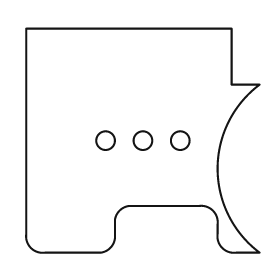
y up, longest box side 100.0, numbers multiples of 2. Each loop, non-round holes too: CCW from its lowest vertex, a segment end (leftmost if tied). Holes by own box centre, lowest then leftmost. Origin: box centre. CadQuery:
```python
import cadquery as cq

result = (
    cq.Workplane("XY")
    .moveTo(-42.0, -48.0)
    .lineTo(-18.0, -48.0)
    .threePointArc((-14.0, -46.0), (-12.0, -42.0))
    .lineTo(-12.0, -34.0)
    .threePointArc((-10.0, -30.0), (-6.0, -28.0))
    .lineTo(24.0, -28.0)
    .threePointArc((30.0, -30.0), (32.0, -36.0))
    .lineTo(32.0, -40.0)
    .threePointArc((34.0, -46.0), (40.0, -48.0))
    .lineTo(50.0, -48.0)
    .threePointArc((32.0, -12.0), (50.0, 24.0))
    .lineTo(38.0, 24.0)
    .lineTo(38.0, 48.0)
    .lineTo(-50.0, 48.0)
    .lineTo(-50.0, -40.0)
    .threePointArc((-48.0, -46.0), (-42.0, -48.0))
    .close()
    .moveTo(-16.0, 0.0)
    .circle(4.0)
    .moveTo(0.0, 0.0)
    .circle(4.0)
    .moveTo(16.0, 0.0)
    .circle(4.0)
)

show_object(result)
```